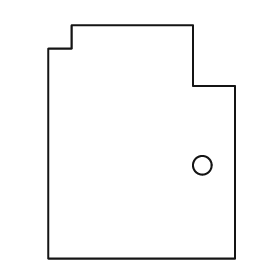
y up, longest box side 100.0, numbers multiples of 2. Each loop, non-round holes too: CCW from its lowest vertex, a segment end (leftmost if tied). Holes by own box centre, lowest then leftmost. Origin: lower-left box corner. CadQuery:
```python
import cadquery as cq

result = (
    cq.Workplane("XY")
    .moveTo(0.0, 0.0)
    .lineTo(80.0, 0.0)
    .lineTo(80.0, 74.0)
    .lineTo(62.0, 74.0)
    .lineTo(62.0, 100.0)
    .lineTo(10.0, 100.0)
    .lineTo(10.0, 90.0)
    .lineTo(0.0, 90.0)
    .close()
    .moveTo(66.0, 40.0)
    .circle(4.0)
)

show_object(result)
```